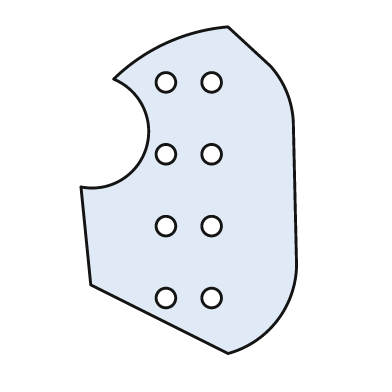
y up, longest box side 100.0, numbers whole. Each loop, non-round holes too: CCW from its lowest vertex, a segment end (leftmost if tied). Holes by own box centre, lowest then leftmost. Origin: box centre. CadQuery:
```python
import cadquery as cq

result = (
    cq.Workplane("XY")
    .moveTo(12.0, -50.0)
    .threePointArc((27.0, -40.0), (33.0, -23.0))
    .lineTo(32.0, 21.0)
    .threePointArc((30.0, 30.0), (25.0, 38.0))
    .lineTo(12.0, 50.0)
    .threePointArc((-7.0, 45.0), (-23.0, 34.0))
    .threePointArc((-13.0, 13.0), (-33.0, 1.0))
    .lineTo(-30.0, -29.0)
    .close()
    .moveTo(-7.0, -33.0)
    .circle(3.0)
    .moveTo(7.0, -33.0)
    .circle(3.0)
    .moveTo(-7.0, -11.0)
    .circle(3.0)
    .moveTo(7.0, -11.0)
    .circle(3.0)
    .moveTo(-7.0, 11.0)
    .circle(3.0)
    .moveTo(7.0, 11.0)
    .circle(3.0)
    .moveTo(-7.0, 33.0)
    .circle(3.0)
    .moveTo(7.0, 33.0)
    .circle(3.0)
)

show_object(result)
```